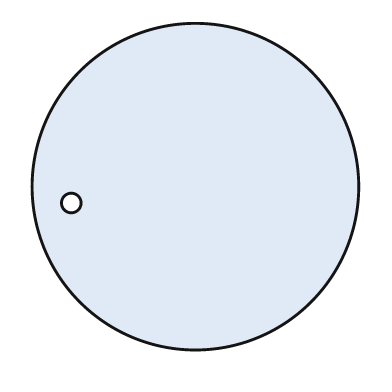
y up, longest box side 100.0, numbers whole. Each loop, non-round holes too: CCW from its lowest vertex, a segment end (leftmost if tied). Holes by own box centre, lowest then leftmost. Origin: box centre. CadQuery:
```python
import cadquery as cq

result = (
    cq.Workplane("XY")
    .moveTo(0.0, 0.0)
    .circle(50.0)
    .moveTo(-38.0, -5.0)
    .circle(3.0)
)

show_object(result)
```